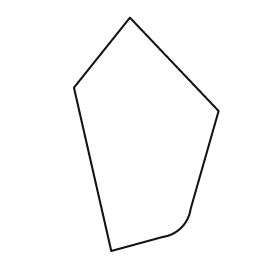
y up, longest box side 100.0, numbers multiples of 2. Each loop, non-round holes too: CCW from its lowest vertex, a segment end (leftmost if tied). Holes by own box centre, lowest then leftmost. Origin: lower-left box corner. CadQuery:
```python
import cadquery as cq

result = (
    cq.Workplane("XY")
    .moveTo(16.0, 0.0)
    .lineTo(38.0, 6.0)
    .threePointArc((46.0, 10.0), (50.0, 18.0))
    .lineTo(62.0, 60.0)
    .lineTo(24.0, 100.0)
    .lineTo(0.0, 70.0)
    .close()
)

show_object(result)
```